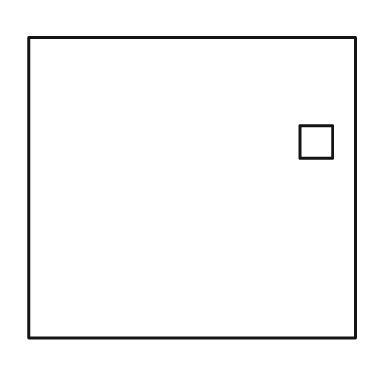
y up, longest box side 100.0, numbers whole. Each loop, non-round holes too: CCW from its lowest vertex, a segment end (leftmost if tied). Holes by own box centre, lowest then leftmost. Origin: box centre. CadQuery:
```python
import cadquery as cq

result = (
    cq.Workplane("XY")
    .moveTo(-50.0, -46.0)
    .lineTo(50.0, -46.0)
    .lineTo(50.0, 46.0)
    .lineTo(-50.0, 46.0)
    .close()
    .moveTo(33.0, 9.0)
    .lineTo(43.0, 9.0)
    .lineTo(43.0, 19.0)
    .lineTo(33.0, 19.0)
    .close()
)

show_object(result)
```